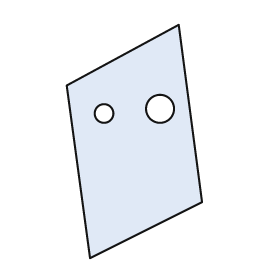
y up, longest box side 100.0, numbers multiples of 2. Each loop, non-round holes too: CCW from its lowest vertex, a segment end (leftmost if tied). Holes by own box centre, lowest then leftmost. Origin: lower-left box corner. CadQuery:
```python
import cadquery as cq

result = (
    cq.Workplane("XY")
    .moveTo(10.0, 0.0)
    .lineTo(58.0, 24.0)
    .lineTo(48.0, 100.0)
    .lineTo(0.0, 74.0)
    .close()
    .moveTo(16.0, 62.0)
    .circle(4.0)
    .moveTo(40.0, 64.0)
    .circle(6.0)
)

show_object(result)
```